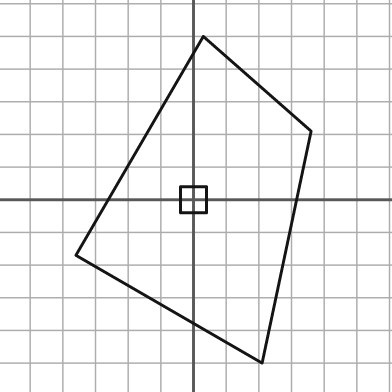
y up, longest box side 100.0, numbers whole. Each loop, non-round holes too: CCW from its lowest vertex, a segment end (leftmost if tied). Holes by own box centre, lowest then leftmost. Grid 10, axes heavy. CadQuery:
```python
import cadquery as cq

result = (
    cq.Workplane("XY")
    .moveTo(21.0, -50.0)
    .lineTo(36.0, 21.0)
    .lineTo(3.0, 50.0)
    .lineTo(-36.0, -17.0)
    .close()
    .moveTo(-4.0, -4.0)
    .lineTo(4.0, -4.0)
    .lineTo(4.0, 4.0)
    .lineTo(-4.0, 4.0)
    .close()
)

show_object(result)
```